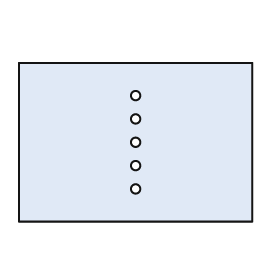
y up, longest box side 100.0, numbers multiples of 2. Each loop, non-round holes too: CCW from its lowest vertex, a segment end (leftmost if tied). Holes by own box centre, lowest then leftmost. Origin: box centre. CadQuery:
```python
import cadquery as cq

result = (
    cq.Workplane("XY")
    .moveTo(-50.0, -34.0)
    .lineTo(50.0, -34.0)
    .lineTo(50.0, 34.0)
    .lineTo(-50.0, 34.0)
    .close()
    .moveTo(0.0, -20.0)
    .circle(2.0)
    .moveTo(0.0, -10.0)
    .circle(2.0)
    .moveTo(0.0, 0.0)
    .circle(2.0)
    .moveTo(0.0, 10.0)
    .circle(2.0)
    .moveTo(0.0, 20.0)
    .circle(2.0)
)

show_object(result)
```